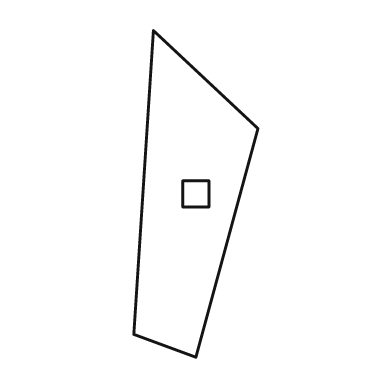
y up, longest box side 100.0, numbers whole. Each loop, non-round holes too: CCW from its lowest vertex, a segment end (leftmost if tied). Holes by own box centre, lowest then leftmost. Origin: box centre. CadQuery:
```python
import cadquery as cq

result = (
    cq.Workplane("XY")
    .moveTo(0.0, -50.0)
    .lineTo(19.0, 20.0)
    .lineTo(-13.0, 50.0)
    .lineTo(-19.0, -43.0)
    .close()
    .moveTo(-4.0, -4.0)
    .lineTo(4.0, -4.0)
    .lineTo(4.0, 4.0)
    .lineTo(-4.0, 4.0)
    .close()
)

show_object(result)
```